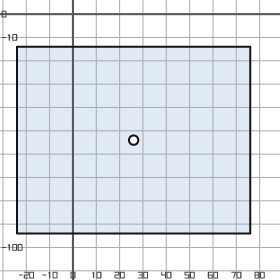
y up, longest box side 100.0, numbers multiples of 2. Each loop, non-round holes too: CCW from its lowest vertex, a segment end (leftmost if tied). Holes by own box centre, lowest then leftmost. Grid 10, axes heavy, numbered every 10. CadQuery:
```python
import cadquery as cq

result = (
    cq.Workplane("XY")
    .moveTo(-24.0, -94.0)
    .lineTo(76.0, -94.0)
    .lineTo(76.0, -14.0)
    .lineTo(-24.0, -14.0)
    .close()
    .moveTo(26.0, -54.0)
    .circle(2.0)
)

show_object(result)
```